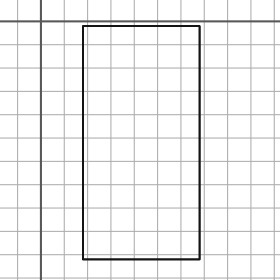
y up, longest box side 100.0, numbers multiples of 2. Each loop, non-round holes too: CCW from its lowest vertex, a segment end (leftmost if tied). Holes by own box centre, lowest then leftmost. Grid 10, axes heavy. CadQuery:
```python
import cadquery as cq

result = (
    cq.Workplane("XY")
    .moveTo(18.0, -102.0)
    .lineTo(68.0, -102.0)
    .lineTo(68.0, -2.0)
    .lineTo(18.0, -2.0)
    .close()
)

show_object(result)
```